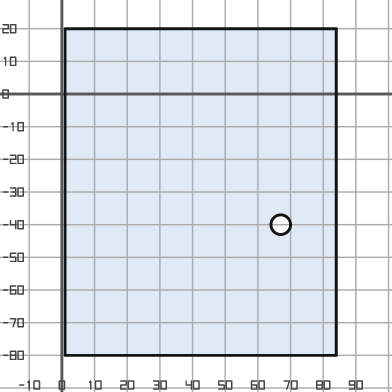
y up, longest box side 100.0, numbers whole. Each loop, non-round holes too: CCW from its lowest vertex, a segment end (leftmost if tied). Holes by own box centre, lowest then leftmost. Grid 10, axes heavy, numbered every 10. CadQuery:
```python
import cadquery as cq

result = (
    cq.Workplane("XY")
    .moveTo(1.0, -80.0)
    .lineTo(84.0, -80.0)
    .lineTo(84.0, 20.0)
    .lineTo(1.0, 20.0)
    .close()
    .moveTo(67.0, -40.0)
    .circle(3.0)
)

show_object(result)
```